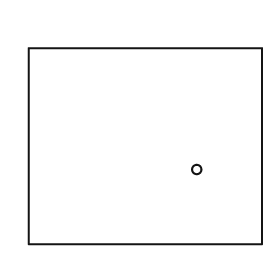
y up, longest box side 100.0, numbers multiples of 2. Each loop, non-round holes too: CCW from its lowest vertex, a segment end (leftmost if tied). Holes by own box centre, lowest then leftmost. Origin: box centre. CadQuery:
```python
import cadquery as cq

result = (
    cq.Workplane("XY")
    .moveTo(-50.0, -42.0)
    .lineTo(50.0, -42.0)
    .lineTo(50.0, 42.0)
    .lineTo(-50.0, 42.0)
    .close()
    .moveTo(22.0, -10.0)
    .circle(2.0)
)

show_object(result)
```